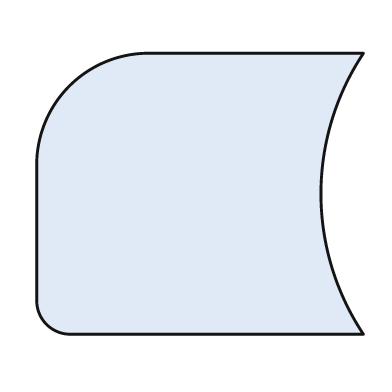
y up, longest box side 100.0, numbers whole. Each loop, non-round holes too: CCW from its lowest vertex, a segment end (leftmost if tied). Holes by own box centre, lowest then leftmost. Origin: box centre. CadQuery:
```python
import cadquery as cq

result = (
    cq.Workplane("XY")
    .moveTo(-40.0, -43.0)
    .lineTo(50.0, -43.0)
    .threePointArc((37.0, 0.0), (50.0, 43.0))
    .lineTo(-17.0, 43.0)
    .threePointArc((-40.0, 33.0), (-50.0, 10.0))
    .lineTo(-50.0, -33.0)
    .threePointArc((-47.0, -40.0), (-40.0, -43.0))
    .close()
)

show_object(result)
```